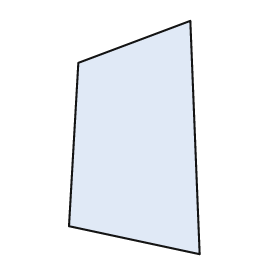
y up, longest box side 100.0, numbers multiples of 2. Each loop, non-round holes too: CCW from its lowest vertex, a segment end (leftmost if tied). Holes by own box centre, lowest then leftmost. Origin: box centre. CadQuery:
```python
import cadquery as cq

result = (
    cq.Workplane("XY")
    .moveTo(28.0, -50.0)
    .lineTo(24.0, 50.0)
    .lineTo(-24.0, 32.0)
    .lineTo(-28.0, -38.0)
    .close()
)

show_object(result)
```